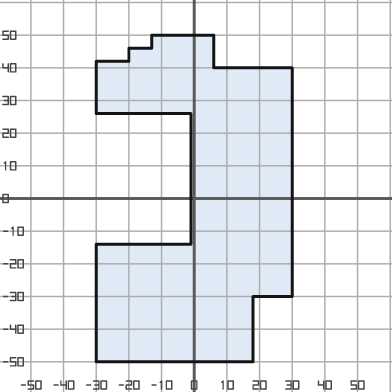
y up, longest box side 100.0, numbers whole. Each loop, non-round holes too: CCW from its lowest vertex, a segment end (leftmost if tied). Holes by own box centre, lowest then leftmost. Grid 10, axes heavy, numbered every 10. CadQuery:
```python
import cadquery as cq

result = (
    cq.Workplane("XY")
    .moveTo(-30.0, -50.0)
    .lineTo(18.0, -50.0)
    .lineTo(18.0, -30.0)
    .lineTo(30.0, -30.0)
    .lineTo(30.0, 40.0)
    .lineTo(6.0, 40.0)
    .lineTo(6.0, 50.0)
    .lineTo(-13.0, 50.0)
    .lineTo(-13.0, 46.0)
    .lineTo(-20.0, 46.0)
    .lineTo(-20.0, 42.0)
    .lineTo(-30.0, 42.0)
    .lineTo(-30.0, 26.0)
    .lineTo(-1.0, 26.0)
    .lineTo(-1.0, -14.0)
    .lineTo(-30.0, -14.0)
    .close()
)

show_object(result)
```